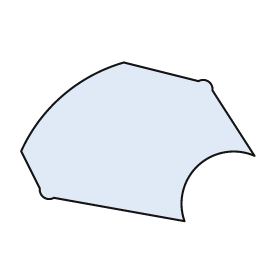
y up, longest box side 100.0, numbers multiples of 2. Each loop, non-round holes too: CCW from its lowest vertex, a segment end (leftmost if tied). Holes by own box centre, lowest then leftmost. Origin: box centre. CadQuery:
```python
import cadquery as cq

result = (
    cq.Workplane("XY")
    .moveTo(20.0, -34.0)
    .threePointArc((26.0, -10.0), (50.0, -6.0))
    .lineTo(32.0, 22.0)
    .threePointArc((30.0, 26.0), (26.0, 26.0))
    .lineTo(-6.0, 34.0)
    .threePointArc((-32.0, 20.0), (-50.0, -4.0))
    .lineTo(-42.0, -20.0)
    .threePointArc((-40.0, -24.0), (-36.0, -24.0))
    .close()
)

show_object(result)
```